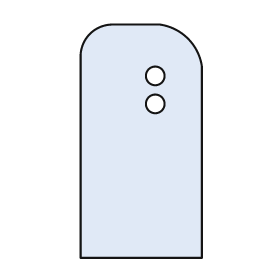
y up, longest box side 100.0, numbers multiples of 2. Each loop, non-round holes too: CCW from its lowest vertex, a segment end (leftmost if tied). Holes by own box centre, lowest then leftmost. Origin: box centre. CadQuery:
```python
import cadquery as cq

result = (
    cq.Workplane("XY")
    .moveTo(-26.0, -50.0)
    .lineTo(26.0, -50.0)
    .lineTo(26.0, 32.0)
    .threePointArc((20.0, 44.0), (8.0, 50.0))
    .lineTo(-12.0, 50.0)
    .threePointArc((-22.0, 46.0), (-26.0, 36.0))
    .close()
    .moveTo(6.0, 16.0)
    .circle(4.0)
    .moveTo(6.0, 28.0)
    .circle(4.0)
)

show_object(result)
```